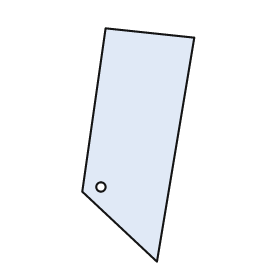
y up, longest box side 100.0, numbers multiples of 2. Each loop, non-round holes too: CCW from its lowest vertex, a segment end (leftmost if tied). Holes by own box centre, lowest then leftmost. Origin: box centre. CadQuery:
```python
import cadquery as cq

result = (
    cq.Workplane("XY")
    .moveTo(8.0, -50.0)
    .lineTo(24.0, 46.0)
    .lineTo(-14.0, 50.0)
    .lineTo(-24.0, -20.0)
    .close()
    .moveTo(-16.0, -18.0)
    .circle(2.0)
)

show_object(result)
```